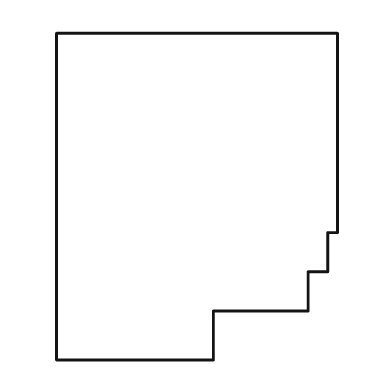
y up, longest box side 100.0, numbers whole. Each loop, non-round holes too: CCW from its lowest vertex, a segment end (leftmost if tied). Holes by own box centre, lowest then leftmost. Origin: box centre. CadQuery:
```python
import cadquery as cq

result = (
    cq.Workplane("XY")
    .moveTo(-43.0, -50.0)
    .lineTo(5.0, -50.0)
    .lineTo(5.0, -35.0)
    .lineTo(34.0, -35.0)
    .lineTo(34.0, -23.0)
    .lineTo(40.0, -23.0)
    .lineTo(40.0, -11.0)
    .lineTo(43.0, -11.0)
    .lineTo(43.0, 50.0)
    .lineTo(-43.0, 50.0)
    .close()
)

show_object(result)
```